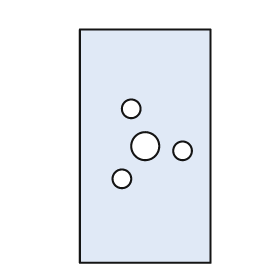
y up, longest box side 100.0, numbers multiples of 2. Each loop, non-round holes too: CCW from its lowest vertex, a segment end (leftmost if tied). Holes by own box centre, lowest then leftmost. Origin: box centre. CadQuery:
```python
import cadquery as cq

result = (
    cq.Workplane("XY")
    .moveTo(-28.0, -50.0)
    .lineTo(28.0, -50.0)
    .lineTo(28.0, 50.0)
    .lineTo(-28.0, 50.0)
    .close()
    .moveTo(-10.0, -14.0)
    .circle(4.0)
    .moveTo(16.0, -2.0)
    .circle(4.0)
    .moveTo(0.0, 0.0)
    .circle(6.0)
    .moveTo(-6.0, 16.0)
    .circle(4.0)
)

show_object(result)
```